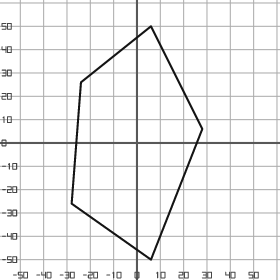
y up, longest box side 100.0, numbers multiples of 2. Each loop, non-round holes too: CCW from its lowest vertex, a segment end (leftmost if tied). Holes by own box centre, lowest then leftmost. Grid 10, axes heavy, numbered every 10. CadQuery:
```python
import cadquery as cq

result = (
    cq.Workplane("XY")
    .moveTo(6.0, -50.0)
    .lineTo(28.0, 6.0)
    .lineTo(6.0, 50.0)
    .lineTo(-24.0, 26.0)
    .lineTo(-28.0, -26.0)
    .close()
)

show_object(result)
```